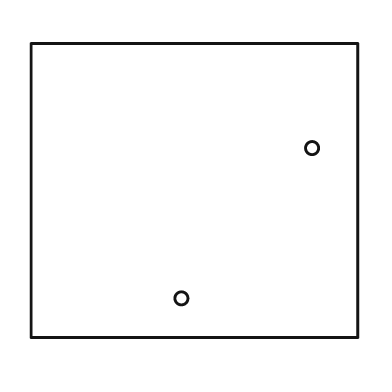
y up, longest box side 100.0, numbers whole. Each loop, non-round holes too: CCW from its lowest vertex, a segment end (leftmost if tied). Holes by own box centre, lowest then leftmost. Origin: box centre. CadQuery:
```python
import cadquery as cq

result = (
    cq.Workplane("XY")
    .moveTo(-50.0, -45.0)
    .lineTo(50.0, -45.0)
    .lineTo(50.0, 45.0)
    .lineTo(-50.0, 45.0)
    .close()
    .moveTo(-4.0, -33.0)
    .circle(2.0)
    .moveTo(36.0, 13.0)
    .circle(2.0)
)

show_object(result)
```